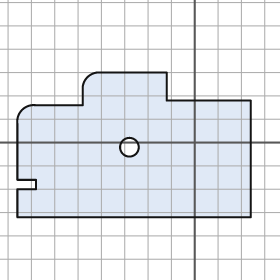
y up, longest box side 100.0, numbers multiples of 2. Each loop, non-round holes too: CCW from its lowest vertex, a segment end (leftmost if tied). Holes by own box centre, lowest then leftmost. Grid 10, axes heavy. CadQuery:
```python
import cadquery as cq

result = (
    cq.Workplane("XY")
    .moveTo(-76.0, -32.0)
    .lineTo(24.0, -32.0)
    .lineTo(24.0, 18.0)
    .lineTo(-12.0, 18.0)
    .lineTo(-12.0, 30.0)
    .lineTo(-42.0, 30.0)
    .threePointArc((-46.0, 28.0), (-48.0, 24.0))
    .lineTo(-48.0, 16.0)
    .lineTo(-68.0, 16.0)
    .threePointArc((-74.0, 14.0), (-76.0, 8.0))
    .lineTo(-76.0, -16.0)
    .lineTo(-68.0, -16.0)
    .lineTo(-68.0, -20.0)
    .lineTo(-76.0, -20.0)
    .close()
    .moveTo(-28.0, -2.0)
    .circle(4.0)
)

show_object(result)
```